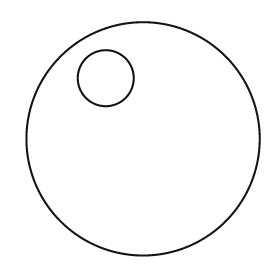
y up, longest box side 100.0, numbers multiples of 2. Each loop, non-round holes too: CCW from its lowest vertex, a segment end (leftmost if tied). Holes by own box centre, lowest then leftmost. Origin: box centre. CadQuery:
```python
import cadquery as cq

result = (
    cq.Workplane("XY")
    .moveTo(0.0, 0.0)
    .circle(50.0)
    .moveTo(-16.0, 26.0)
    .circle(12.0)
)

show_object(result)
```